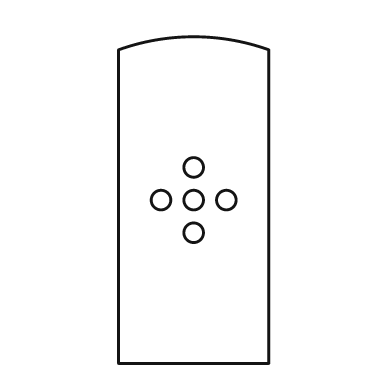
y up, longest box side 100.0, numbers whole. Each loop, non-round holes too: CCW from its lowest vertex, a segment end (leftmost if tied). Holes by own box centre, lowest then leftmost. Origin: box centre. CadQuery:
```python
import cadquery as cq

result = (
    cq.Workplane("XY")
    .moveTo(-23.0, -50.0)
    .lineTo(23.0, -50.0)
    .lineTo(23.0, 46.0)
    .threePointArc((0.0, 50.0), (-23.0, 46.0))
    .close()
    .moveTo(0.0, -10.0)
    .circle(3.0)
    .moveTo(-10.0, 0.0)
    .circle(3.0)
    .moveTo(0.0, 0.0)
    .circle(3.0)
    .moveTo(10.0, 0.0)
    .circle(3.0)
    .moveTo(0.0, 10.0)
    .circle(3.0)
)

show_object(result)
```